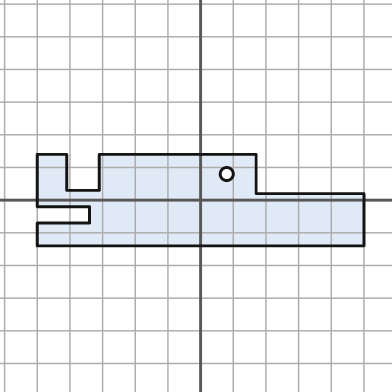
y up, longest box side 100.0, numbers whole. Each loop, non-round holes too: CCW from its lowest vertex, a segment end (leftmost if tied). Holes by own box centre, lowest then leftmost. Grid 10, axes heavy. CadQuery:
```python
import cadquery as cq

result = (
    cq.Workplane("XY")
    .moveTo(-50.0, -14.0)
    .lineTo(50.0, -14.0)
    .lineTo(50.0, 2.0)
    .lineTo(17.0, 2.0)
    .lineTo(17.0, 14.0)
    .lineTo(-31.0, 14.0)
    .lineTo(-31.0, 3.0)
    .lineTo(-41.0, 3.0)
    .lineTo(-41.0, 14.0)
    .lineTo(-50.0, 14.0)
    .lineTo(-50.0, -2.0)
    .lineTo(-34.0, -2.0)
    .lineTo(-34.0, -7.0)
    .lineTo(-50.0, -7.0)
    .close()
    .moveTo(8.0, 8.0)
    .circle(2.0)
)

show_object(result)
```